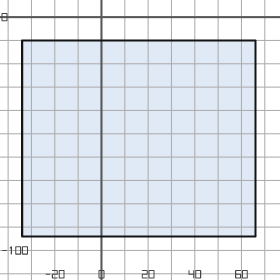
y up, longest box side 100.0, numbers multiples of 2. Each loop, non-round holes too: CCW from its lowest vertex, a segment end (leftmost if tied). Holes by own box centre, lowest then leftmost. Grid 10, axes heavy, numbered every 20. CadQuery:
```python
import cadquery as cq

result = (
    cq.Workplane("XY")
    .moveTo(-34.0, -94.0)
    .lineTo(66.0, -94.0)
    .lineTo(66.0, -10.0)
    .lineTo(-34.0, -10.0)
    .close()
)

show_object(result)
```